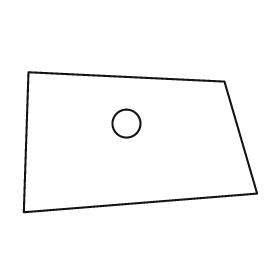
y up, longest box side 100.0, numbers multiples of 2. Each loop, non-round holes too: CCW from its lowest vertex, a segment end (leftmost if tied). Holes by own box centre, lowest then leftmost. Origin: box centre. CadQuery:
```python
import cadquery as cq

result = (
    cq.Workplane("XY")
    .moveTo(-50.0, -30.0)
    .lineTo(50.0, -22.0)
    .lineTo(36.0, 26.0)
    .lineTo(-48.0, 30.0)
    .close()
    .moveTo(-6.0, 8.0)
    .circle(6.0)
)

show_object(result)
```